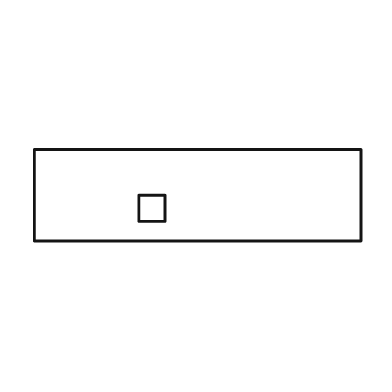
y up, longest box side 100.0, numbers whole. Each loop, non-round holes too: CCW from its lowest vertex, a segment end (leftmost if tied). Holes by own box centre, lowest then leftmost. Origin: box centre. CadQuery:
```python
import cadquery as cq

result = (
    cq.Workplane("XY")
    .moveTo(-50.0, -14.0)
    .lineTo(50.0, -14.0)
    .lineTo(50.0, 14.0)
    .lineTo(-50.0, 14.0)
    .close()
    .moveTo(-18.0, -8.0)
    .lineTo(-10.0, -8.0)
    .lineTo(-10.0, 0.0)
    .lineTo(-18.0, 0.0)
    .close()
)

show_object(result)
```